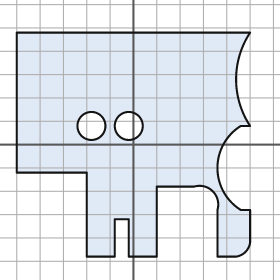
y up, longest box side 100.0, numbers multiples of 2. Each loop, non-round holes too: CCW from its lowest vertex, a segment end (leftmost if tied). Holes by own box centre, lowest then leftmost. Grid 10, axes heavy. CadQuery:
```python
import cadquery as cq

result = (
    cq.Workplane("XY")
    .moveTo(-20.0, -48.0)
    .lineTo(-8.0, -48.0)
    .lineTo(-8.0, -32.0)
    .lineTo(-2.0, -32.0)
    .lineTo(-2.0, -48.0)
    .lineTo(10.0, -48.0)
    .lineTo(10.0, -18.0)
    .lineTo(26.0, -18.0)
    .threePointArc((34.0, -20.0), (36.0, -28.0))
    .lineTo(36.0, -48.0)
    .lineTo(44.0, -48.0)
    .threePointArc((48.0, -46.0), (50.0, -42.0))
    .lineTo(50.0, -28.0)
    .lineTo(46.0, -28.0)
    .threePointArc((36.0, -10.0), (46.0, 8.0))
    .lineTo(50.0, 8.0)
    .threePointArc((44.0, 28.0), (50.0, 48.0))
    .lineTo(-50.0, 48.0)
    .lineTo(-50.0, -12.0)
    .lineTo(-20.0, -12.0)
    .close()
    .moveTo(-18.0, 8.0)
    .circle(6.0)
    .moveTo(-2.0, 8.0)
    .circle(6.0)
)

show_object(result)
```